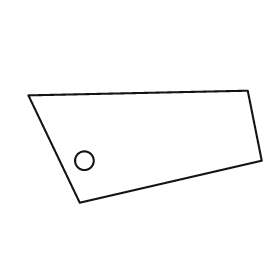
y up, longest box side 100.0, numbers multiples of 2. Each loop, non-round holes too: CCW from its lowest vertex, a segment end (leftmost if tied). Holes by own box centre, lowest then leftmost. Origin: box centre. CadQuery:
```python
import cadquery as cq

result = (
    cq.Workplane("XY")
    .moveTo(-28.0, -24.0)
    .lineTo(50.0, -6.0)
    .lineTo(44.0, 24.0)
    .lineTo(-50.0, 22.0)
    .close()
    .moveTo(-26.0, -6.0)
    .circle(4.0)
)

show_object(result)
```